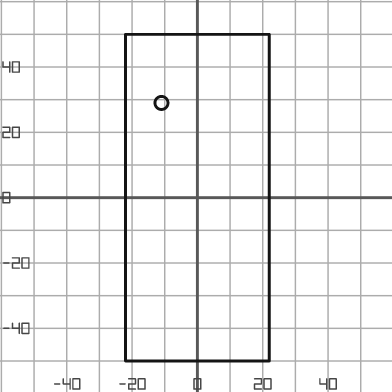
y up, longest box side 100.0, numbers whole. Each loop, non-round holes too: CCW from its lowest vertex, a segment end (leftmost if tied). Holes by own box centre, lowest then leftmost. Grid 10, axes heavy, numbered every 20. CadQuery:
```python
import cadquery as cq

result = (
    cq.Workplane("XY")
    .moveTo(-22.0, -50.0)
    .lineTo(22.0, -50.0)
    .lineTo(22.0, 50.0)
    .lineTo(-22.0, 50.0)
    .close()
    .moveTo(-11.0, 29.0)
    .circle(2.0)
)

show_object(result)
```